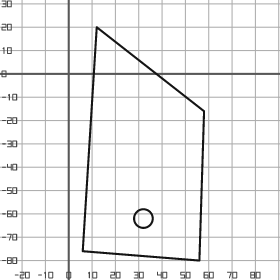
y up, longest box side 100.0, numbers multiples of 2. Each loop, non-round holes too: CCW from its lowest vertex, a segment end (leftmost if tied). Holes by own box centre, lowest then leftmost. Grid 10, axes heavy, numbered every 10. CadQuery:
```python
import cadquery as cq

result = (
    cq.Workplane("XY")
    .moveTo(56.0, -80.0)
    .lineTo(58.0, -16.0)
    .lineTo(12.0, 20.0)
    .lineTo(6.0, -76.0)
    .close()
    .moveTo(32.0, -62.0)
    .circle(4.0)
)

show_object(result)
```